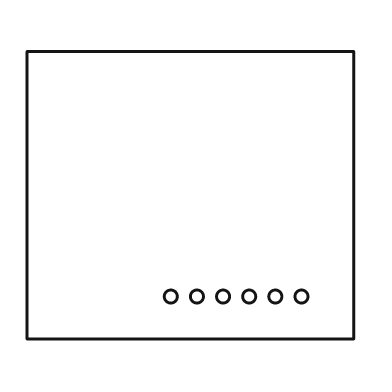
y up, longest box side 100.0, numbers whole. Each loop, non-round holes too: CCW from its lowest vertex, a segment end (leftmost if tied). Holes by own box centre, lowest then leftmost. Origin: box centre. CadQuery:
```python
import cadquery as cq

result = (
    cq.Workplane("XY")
    .moveTo(-50.0, -44.0)
    .lineTo(50.0, -44.0)
    .lineTo(50.0, 44.0)
    .lineTo(-50.0, 44.0)
    .close()
    .moveTo(-6.0, -31.0)
    .circle(2.0)
    .moveTo(2.0, -31.0)
    .circle(2.0)
    .moveTo(10.0, -31.0)
    .circle(2.0)
    .moveTo(18.0, -31.0)
    .circle(2.0)
    .moveTo(26.0, -31.0)
    .circle(2.0)
    .moveTo(34.0, -31.0)
    .circle(2.0)
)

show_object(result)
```